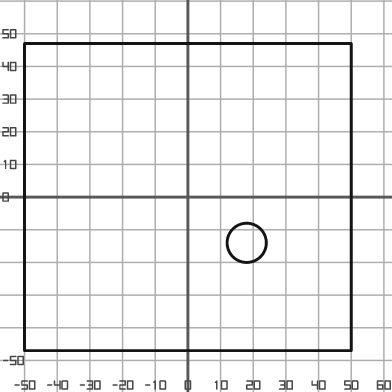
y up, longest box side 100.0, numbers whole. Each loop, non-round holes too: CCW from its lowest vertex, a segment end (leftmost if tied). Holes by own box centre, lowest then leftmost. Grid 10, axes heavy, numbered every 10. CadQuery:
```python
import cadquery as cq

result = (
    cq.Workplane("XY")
    .moveTo(-50.0, -47.0)
    .lineTo(50.0, -47.0)
    .lineTo(50.0, 47.0)
    .lineTo(-50.0, 47.0)
    .close()
    .moveTo(18.0, -14.0)
    .circle(6.0)
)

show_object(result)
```